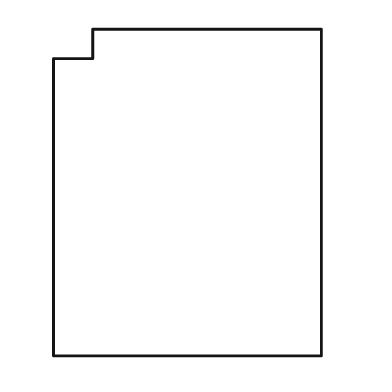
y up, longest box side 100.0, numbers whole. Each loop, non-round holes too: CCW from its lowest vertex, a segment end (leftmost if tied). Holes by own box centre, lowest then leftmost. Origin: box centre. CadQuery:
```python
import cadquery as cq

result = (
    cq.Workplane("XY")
    .moveTo(-41.0, -50.0)
    .lineTo(41.0, -50.0)
    .lineTo(41.0, 50.0)
    .lineTo(-29.0, 50.0)
    .lineTo(-29.0, 41.0)
    .lineTo(-41.0, 41.0)
    .close()
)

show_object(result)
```